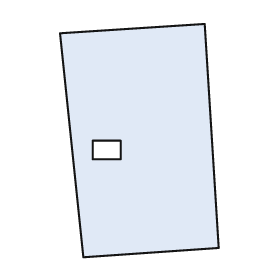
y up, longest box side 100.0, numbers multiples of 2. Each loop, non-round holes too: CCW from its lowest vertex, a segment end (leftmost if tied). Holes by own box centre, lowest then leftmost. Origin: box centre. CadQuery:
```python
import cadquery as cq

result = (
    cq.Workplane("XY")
    .moveTo(-24.0, -50.0)
    .lineTo(34.0, -46.0)
    .lineTo(28.0, 50.0)
    .lineTo(-34.0, 46.0)
    .close()
    .moveTo(-20.0, -8.0)
    .lineTo(-8.0, -8.0)
    .lineTo(-8.0, 0.0)
    .lineTo(-20.0, 0.0)
    .close()
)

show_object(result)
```